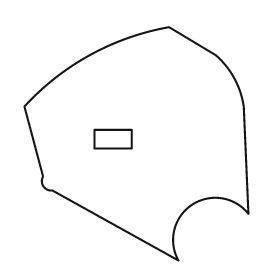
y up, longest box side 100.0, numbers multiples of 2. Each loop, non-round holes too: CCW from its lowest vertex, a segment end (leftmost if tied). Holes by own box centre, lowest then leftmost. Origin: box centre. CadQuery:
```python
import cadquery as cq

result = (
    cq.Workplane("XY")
    .moveTo(18.0, -50.0)
    .threePointArc((24.0, -26.0), (48.0, -30.0))
    .lineTo(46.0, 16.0)
    .threePointArc((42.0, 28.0), (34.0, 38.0))
    .lineTo(14.0, 50.0)
    .threePointArc((-20.0, 38.0), (-48.0, 16.0))
    .lineTo(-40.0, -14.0)
    .threePointArc((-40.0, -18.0), (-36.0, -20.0))
    .close()
    .moveTo(-18.0, -2.0)
    .lineTo(-2.0, -2.0)
    .lineTo(-2.0, 6.0)
    .lineTo(-18.0, 6.0)
    .close()
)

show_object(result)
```